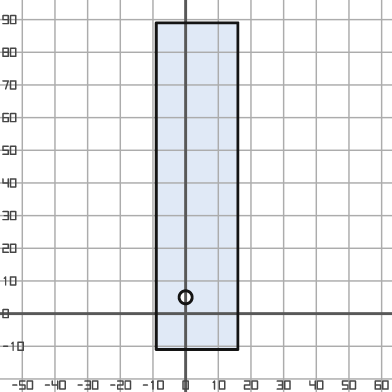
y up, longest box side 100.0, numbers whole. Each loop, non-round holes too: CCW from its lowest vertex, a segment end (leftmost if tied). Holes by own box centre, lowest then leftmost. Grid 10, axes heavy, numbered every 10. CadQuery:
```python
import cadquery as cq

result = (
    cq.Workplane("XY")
    .moveTo(-9.0, -11.0)
    .lineTo(16.0, -11.0)
    .lineTo(16.0, 89.0)
    .lineTo(-9.0, 89.0)
    .close()
    .moveTo(0.0, 5.0)
    .circle(2.0)
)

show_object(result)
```